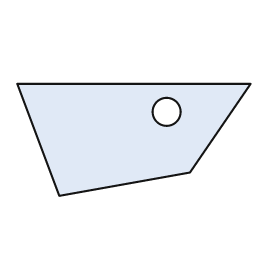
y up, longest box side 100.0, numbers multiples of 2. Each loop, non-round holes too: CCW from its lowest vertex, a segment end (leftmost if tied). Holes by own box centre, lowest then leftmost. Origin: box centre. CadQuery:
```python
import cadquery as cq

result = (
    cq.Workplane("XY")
    .moveTo(-32.0, -24.0)
    .lineTo(24.0, -14.0)
    .lineTo(50.0, 24.0)
    .lineTo(-50.0, 24.0)
    .close()
    .moveTo(14.0, 12.0)
    .circle(6.0)
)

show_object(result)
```